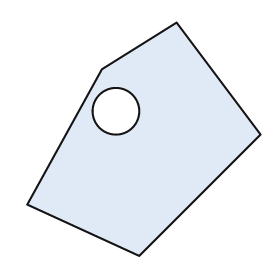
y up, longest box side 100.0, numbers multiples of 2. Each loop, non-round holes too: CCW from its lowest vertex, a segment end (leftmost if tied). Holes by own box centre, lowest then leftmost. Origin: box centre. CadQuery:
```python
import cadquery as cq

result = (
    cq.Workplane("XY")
    .moveTo(-2.0, -50.0)
    .lineTo(50.0, 2.0)
    .lineTo(14.0, 50.0)
    .lineTo(-18.0, 30.0)
    .lineTo(-50.0, -28.0)
    .close()
    .moveTo(-12.0, 12.0)
    .circle(10.0)
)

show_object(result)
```